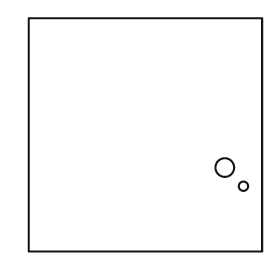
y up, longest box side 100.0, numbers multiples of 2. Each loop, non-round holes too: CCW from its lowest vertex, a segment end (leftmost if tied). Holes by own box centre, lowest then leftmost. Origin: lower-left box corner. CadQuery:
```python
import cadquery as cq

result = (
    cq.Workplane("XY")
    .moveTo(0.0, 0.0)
    .lineTo(100.0, 0.0)
    .lineTo(100.0, 100.0)
    .lineTo(0.0, 100.0)
    .close()
    .moveTo(92.0, 28.0)
    .circle(2.0)
    .moveTo(84.0, 36.0)
    .circle(4.0)
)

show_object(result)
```